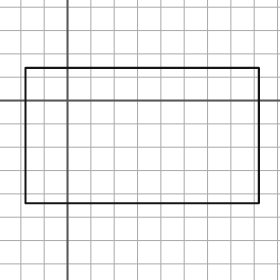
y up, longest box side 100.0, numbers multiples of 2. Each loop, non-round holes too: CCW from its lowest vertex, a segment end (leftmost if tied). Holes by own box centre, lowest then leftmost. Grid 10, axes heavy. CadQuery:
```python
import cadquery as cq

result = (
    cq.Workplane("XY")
    .moveTo(-18.0, -44.0)
    .lineTo(82.0, -44.0)
    .lineTo(82.0, 14.0)
    .lineTo(-18.0, 14.0)
    .close()
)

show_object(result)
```